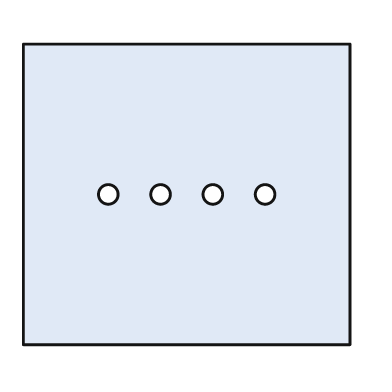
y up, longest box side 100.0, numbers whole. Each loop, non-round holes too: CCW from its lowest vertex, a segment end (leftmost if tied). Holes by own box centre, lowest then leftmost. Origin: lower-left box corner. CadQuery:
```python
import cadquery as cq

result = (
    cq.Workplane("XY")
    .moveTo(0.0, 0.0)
    .lineTo(100.0, 0.0)
    .lineTo(100.0, 92.0)
    .lineTo(0.0, 92.0)
    .close()
    .moveTo(26.0, 46.0)
    .circle(3.0)
    .moveTo(42.0, 46.0)
    .circle(3.0)
    .moveTo(58.0, 46.0)
    .circle(3.0)
    .moveTo(74.0, 46.0)
    .circle(3.0)
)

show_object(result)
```